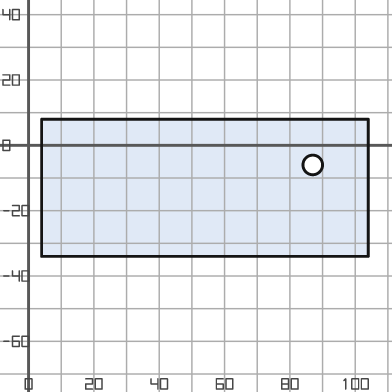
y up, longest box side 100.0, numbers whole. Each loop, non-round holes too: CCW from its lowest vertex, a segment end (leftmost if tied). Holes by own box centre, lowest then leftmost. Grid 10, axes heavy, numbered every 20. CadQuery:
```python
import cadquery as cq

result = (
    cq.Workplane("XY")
    .moveTo(4.0, -34.0)
    .lineTo(104.0, -34.0)
    .lineTo(104.0, 8.0)
    .lineTo(4.0, 8.0)
    .close()
    .moveTo(87.0, -6.0)
    .circle(3.0)
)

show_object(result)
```